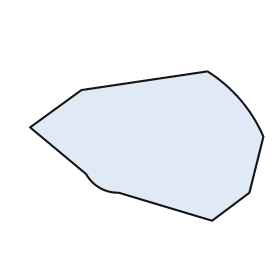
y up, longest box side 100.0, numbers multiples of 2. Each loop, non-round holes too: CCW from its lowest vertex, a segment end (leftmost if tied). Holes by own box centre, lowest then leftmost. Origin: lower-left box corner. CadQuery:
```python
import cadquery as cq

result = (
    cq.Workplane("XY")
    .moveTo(78.0, 0.0)
    .lineTo(94.0, 12.0)
    .lineTo(100.0, 36.0)
    .threePointArc((90.0, 52.0), (76.0, 64.0))
    .lineTo(22.0, 56.0)
    .lineTo(0.0, 40.0)
    .lineTo(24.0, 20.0)
    .threePointArc((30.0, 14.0), (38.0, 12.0))
    .close()
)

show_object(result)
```